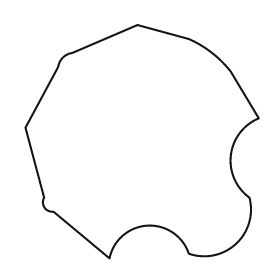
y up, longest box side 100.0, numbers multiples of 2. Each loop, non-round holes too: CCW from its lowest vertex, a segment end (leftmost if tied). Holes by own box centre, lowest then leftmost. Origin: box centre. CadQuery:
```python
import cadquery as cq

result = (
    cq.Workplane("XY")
    .moveTo(-14.0, -50.0)
    .threePointArc((2.0, -36.0), (20.0, -48.0))
    .threePointArc((40.0, -44.0), (46.0, -24.0))
    .threePointArc((38.0, -6.0), (50.0, 10.0))
    .lineTo(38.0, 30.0)
    .threePointArc((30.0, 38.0), (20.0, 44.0))
    .lineTo(-2.0, 50.0)
    .lineTo(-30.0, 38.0)
    .threePointArc((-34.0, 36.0), (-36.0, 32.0))
    .lineTo(-50.0, 6.0)
    .lineTo(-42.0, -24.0)
    .threePointArc((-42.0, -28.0), (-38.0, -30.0))
    .close()
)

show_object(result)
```